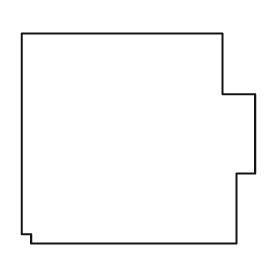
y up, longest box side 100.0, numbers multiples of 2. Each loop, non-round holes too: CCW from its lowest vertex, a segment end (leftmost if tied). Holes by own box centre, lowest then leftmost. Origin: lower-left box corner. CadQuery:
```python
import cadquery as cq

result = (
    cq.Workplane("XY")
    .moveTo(4.0, 0.0)
    .lineTo(92.0, 0.0)
    .lineTo(92.0, 30.0)
    .lineTo(100.0, 30.0)
    .lineTo(100.0, 64.0)
    .lineTo(86.0, 64.0)
    .lineTo(86.0, 90.0)
    .lineTo(0.0, 90.0)
    .lineTo(0.0, 4.0)
    .lineTo(4.0, 4.0)
    .close()
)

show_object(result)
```